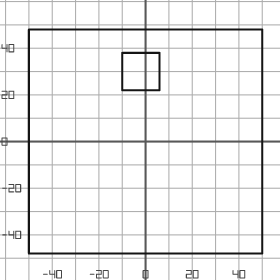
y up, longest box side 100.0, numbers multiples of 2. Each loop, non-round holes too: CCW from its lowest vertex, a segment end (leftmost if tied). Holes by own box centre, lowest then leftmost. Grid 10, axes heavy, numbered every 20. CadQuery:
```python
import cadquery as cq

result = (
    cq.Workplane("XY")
    .moveTo(-50.0, -48.0)
    .lineTo(50.0, -48.0)
    .lineTo(50.0, 48.0)
    .lineTo(-50.0, 48.0)
    .close()
    .moveTo(-10.0, 22.0)
    .lineTo(6.0, 22.0)
    .lineTo(6.0, 38.0)
    .lineTo(-10.0, 38.0)
    .close()
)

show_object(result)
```